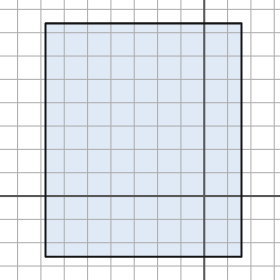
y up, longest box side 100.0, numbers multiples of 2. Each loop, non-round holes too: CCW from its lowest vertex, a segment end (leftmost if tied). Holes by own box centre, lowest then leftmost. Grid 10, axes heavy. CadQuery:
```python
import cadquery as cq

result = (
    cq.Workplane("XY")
    .moveTo(-68.0, -26.0)
    .lineTo(16.0, -26.0)
    .lineTo(16.0, 74.0)
    .lineTo(-68.0, 74.0)
    .close()
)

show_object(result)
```